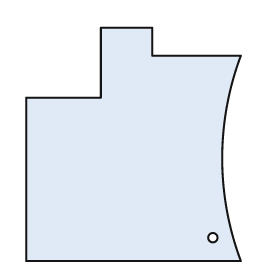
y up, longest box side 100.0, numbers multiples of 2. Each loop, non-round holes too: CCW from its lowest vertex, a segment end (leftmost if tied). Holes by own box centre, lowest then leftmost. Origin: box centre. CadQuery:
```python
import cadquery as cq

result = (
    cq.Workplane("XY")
    .moveTo(-46.0, -50.0)
    .lineTo(46.0, -50.0)
    .threePointArc((38.0, -6.0), (46.0, 38.0))
    .lineTo(8.0, 38.0)
    .lineTo(8.0, 50.0)
    .lineTo(-14.0, 50.0)
    .lineTo(-14.0, 20.0)
    .lineTo(-46.0, 20.0)
    .close()
    .moveTo(34.0, -40.0)
    .circle(2.0)
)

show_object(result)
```